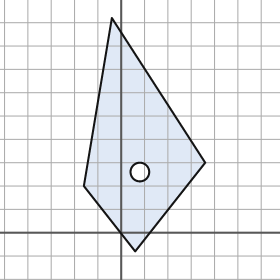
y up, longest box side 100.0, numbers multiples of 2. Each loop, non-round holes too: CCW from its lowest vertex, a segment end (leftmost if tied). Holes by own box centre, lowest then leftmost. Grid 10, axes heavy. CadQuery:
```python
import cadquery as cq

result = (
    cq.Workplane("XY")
    .moveTo(6.0, -8.0)
    .lineTo(36.0, 30.0)
    .lineTo(-4.0, 92.0)
    .lineTo(-16.0, 20.0)
    .close()
    .moveTo(8.0, 26.0)
    .circle(4.0)
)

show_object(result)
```